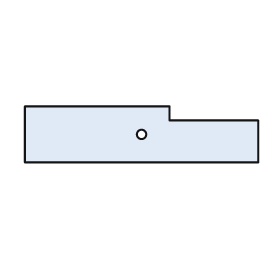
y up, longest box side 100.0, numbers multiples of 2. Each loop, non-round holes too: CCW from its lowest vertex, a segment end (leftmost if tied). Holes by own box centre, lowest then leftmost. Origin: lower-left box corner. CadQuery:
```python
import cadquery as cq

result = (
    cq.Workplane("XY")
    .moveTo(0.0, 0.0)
    .lineTo(100.0, 0.0)
    .lineTo(100.0, 18.0)
    .lineTo(62.0, 18.0)
    .lineTo(62.0, 24.0)
    .lineTo(0.0, 24.0)
    .close()
    .moveTo(50.0, 12.0)
    .circle(2.0)
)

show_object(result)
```